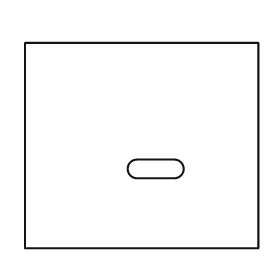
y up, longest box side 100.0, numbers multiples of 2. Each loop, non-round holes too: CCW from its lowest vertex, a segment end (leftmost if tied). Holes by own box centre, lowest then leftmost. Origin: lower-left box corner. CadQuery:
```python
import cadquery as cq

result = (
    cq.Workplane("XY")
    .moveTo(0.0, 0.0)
    .lineTo(100.0, 0.0)
    .lineTo(100.0, 88.0)
    .lineTo(0.0, 88.0)
    .close()
    .moveTo(48.0, 30.0)
    .lineTo(64.0, 30.0)
    .threePointArc((68.0, 34.0), (64.0, 38.0))
    .lineTo(48.0, 38.0)
    .threePointArc((44.0, 34.0), (48.0, 30.0))
    .close()
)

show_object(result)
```